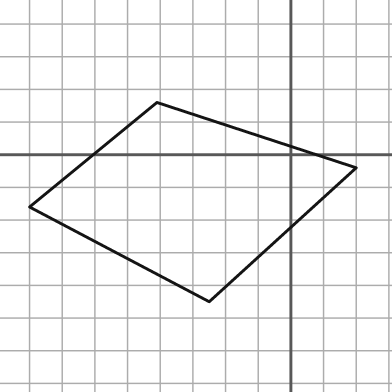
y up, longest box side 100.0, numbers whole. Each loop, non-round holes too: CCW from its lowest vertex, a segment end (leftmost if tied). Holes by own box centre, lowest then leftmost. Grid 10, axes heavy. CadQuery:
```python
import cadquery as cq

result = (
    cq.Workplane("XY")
    .moveTo(-25.0, -45.0)
    .lineTo(20.0, -4.0)
    .lineTo(-41.0, 16.0)
    .lineTo(-80.0, -16.0)
    .close()
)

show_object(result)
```